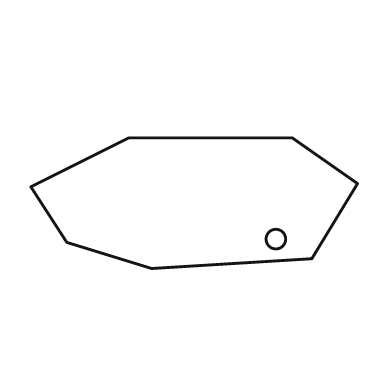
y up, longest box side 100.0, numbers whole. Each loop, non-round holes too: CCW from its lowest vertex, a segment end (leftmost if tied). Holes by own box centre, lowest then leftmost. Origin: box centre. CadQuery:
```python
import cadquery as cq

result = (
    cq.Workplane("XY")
    .moveTo(-13.0, -20.0)
    .lineTo(36.0, -17.0)
    .lineTo(50.0, 6.0)
    .lineTo(30.0, 20.0)
    .lineTo(-20.0, 20.0)
    .lineTo(-50.0, 5.0)
    .lineTo(-39.0, -12.0)
    .close()
    .moveTo(25.0, -11.0)
    .circle(3.0)
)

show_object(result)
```